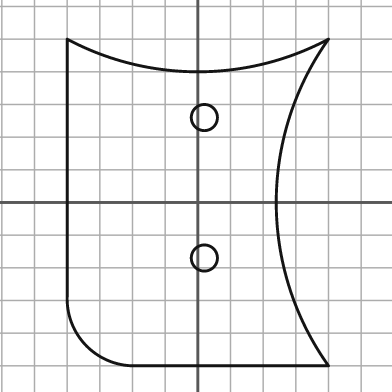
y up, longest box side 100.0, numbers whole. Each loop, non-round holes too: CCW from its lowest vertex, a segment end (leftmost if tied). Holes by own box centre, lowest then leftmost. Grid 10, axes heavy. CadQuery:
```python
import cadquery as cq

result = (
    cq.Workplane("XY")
    .moveTo(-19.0, -50.0)
    .lineTo(40.0, -50.0)
    .threePointArc((24.0, 0.0), (40.0, 50.0))
    .threePointArc((0.0, 40.0), (-40.0, 50.0))
    .lineTo(-40.0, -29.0)
    .threePointArc((-34.0, -44.0), (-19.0, -50.0))
    .close()
    .moveTo(2.0, -17.0)
    .circle(4.0)
    .moveTo(2.0, 26.0)
    .circle(4.0)
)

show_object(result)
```